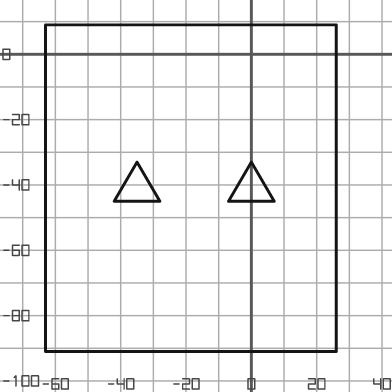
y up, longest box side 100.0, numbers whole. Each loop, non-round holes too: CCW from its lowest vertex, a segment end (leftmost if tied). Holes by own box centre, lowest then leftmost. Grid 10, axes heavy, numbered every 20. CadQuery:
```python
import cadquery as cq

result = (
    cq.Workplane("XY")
    .moveTo(-63.0, -91.0)
    .lineTo(26.0, -91.0)
    .lineTo(26.0, 9.0)
    .lineTo(-63.0, 9.0)
    .close()
    .moveTo(-42.0, -45.0)
    .lineTo(-28.0, -45.0)
    .lineTo(-35.0, -33.0)
    .close()
    .moveTo(-7.0, -45.0)
    .lineTo(7.0, -45.0)
    .lineTo(0.0, -33.0)
    .close()
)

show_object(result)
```